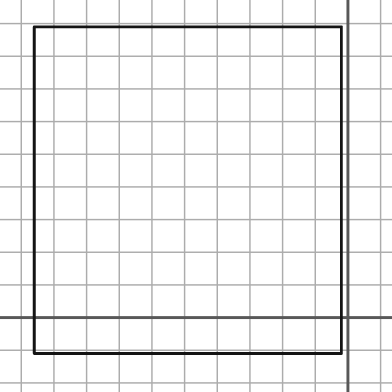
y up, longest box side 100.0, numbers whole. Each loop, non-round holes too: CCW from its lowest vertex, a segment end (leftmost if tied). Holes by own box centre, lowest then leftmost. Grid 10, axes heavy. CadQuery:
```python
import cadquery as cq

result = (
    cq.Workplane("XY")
    .moveTo(-96.0, -11.0)
    .lineTo(-2.0, -11.0)
    .lineTo(-2.0, 89.0)
    .lineTo(-96.0, 89.0)
    .close()
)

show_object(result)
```